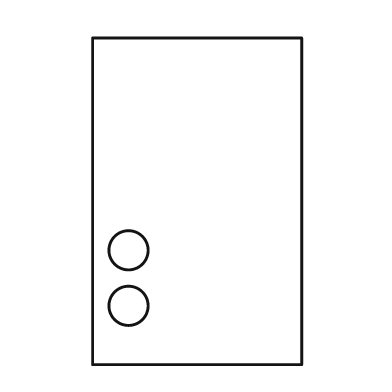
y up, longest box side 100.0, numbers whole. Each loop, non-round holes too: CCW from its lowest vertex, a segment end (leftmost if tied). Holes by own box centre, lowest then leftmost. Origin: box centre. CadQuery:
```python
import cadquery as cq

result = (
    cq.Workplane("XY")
    .moveTo(-32.0, -50.0)
    .lineTo(32.0, -50.0)
    .lineTo(32.0, 50.0)
    .lineTo(-32.0, 50.0)
    .close()
    .moveTo(-21.0, -32.0)
    .circle(6.0)
    .moveTo(-21.0, -15.0)
    .circle(6.0)
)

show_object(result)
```